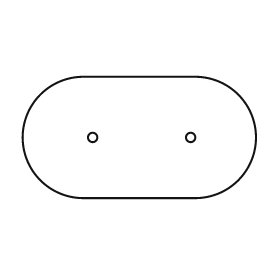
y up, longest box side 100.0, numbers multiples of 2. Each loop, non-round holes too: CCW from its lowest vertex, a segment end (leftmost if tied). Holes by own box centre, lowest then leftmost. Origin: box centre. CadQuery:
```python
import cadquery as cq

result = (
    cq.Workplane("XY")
    .moveTo(-24.0, -26.0)
    .lineTo(24.0, -26.0)
    .threePointArc((50.0, 0.0), (24.0, 26.0))
    .lineTo(-24.0, 26.0)
    .threePointArc((-50.0, 0.0), (-24.0, -26.0))
    .close()
    .moveTo(-20.0, 0.0)
    .circle(2.0)
    .moveTo(22.0, 0.0)
    .circle(2.0)
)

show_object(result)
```